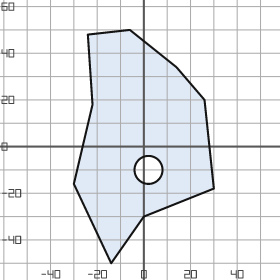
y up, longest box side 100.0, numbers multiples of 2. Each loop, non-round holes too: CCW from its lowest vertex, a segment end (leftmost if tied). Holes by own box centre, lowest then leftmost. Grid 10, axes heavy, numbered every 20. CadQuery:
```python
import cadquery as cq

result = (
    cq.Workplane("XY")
    .moveTo(-14.0, -50.0)
    .lineTo(0.0, -30.0)
    .lineTo(30.0, -18.0)
    .lineTo(26.0, 20.0)
    .lineTo(14.0, 34.0)
    .lineTo(-6.0, 50.0)
    .lineTo(-24.0, 48.0)
    .lineTo(-22.0, 18.0)
    .lineTo(-30.0, -16.0)
    .close()
    .moveTo(2.0, -10.0)
    .circle(6.0)
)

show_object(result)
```